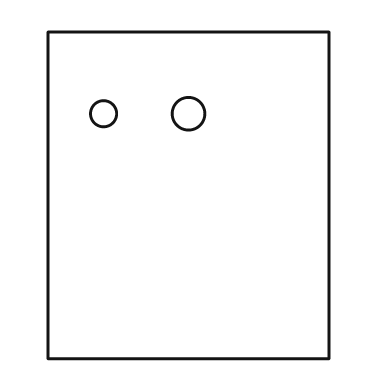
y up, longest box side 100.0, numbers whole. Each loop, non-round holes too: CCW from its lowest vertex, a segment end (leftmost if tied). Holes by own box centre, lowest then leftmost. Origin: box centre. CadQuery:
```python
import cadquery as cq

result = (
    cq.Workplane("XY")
    .moveTo(-43.0, -50.0)
    .lineTo(43.0, -50.0)
    .lineTo(43.0, 50.0)
    .lineTo(-43.0, 50.0)
    .close()
    .moveTo(-26.0, 25.0)
    .circle(4.0)
    .moveTo(0.0, 25.0)
    .circle(5.0)
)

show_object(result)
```